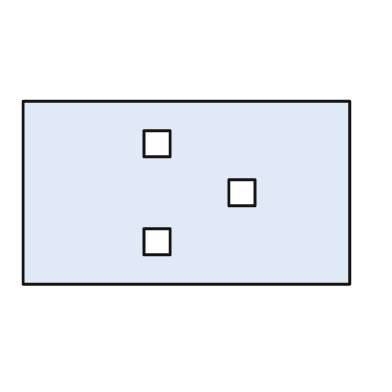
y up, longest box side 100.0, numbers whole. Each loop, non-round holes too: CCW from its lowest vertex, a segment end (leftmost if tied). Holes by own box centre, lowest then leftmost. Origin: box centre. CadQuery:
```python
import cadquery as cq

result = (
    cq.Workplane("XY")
    .moveTo(-50.0, -28.0)
    .lineTo(50.0, -28.0)
    .lineTo(50.0, 28.0)
    .lineTo(-50.0, 28.0)
    .close()
    .moveTo(-13.0, -19.0)
    .lineTo(-5.0, -19.0)
    .lineTo(-5.0, -11.0)
    .lineTo(-13.0, -11.0)
    .close()
    .moveTo(13.0, -4.0)
    .lineTo(21.0, -4.0)
    .lineTo(21.0, 4.0)
    .lineTo(13.0, 4.0)
    .close()
    .moveTo(-13.0, 11.0)
    .lineTo(-5.0, 11.0)
    .lineTo(-5.0, 19.0)
    .lineTo(-13.0, 19.0)
    .close()
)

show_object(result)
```